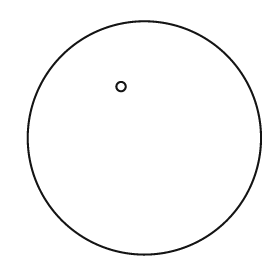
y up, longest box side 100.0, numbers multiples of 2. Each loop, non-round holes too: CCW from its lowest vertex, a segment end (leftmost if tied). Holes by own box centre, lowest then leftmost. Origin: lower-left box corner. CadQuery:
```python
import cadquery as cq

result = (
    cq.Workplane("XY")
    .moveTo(50.0, 50.0)
    .circle(50.0)
    .moveTo(40.0, 72.0)
    .circle(2.0)
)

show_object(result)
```